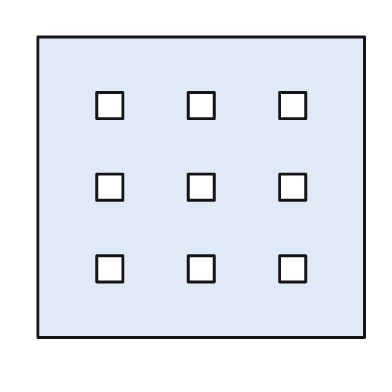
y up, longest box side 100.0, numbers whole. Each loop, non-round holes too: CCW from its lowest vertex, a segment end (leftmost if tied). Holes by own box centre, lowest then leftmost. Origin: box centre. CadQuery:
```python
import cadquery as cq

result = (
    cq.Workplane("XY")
    .moveTo(-50.0, -46.0)
    .lineTo(50.0, -46.0)
    .lineTo(50.0, 46.0)
    .lineTo(-50.0, 46.0)
    .close()
    .moveTo(-32.0, -29.0)
    .lineTo(-24.0, -29.0)
    .lineTo(-24.0, -21.0)
    .lineTo(-32.0, -21.0)
    .close()
    .moveTo(-4.0, -29.0)
    .lineTo(4.0, -29.0)
    .lineTo(4.0, -21.0)
    .lineTo(-4.0, -21.0)
    .close()
    .moveTo(24.0, -29.0)
    .lineTo(32.0, -29.0)
    .lineTo(32.0, -21.0)
    .lineTo(24.0, -21.0)
    .close()
    .moveTo(-32.0, -4.0)
    .lineTo(-24.0, -4.0)
    .lineTo(-24.0, 4.0)
    .lineTo(-32.0, 4.0)
    .close()
    .moveTo(-4.0, -4.0)
    .lineTo(4.0, -4.0)
    .lineTo(4.0, 4.0)
    .lineTo(-4.0, 4.0)
    .close()
    .moveTo(24.0, -4.0)
    .lineTo(32.0, -4.0)
    .lineTo(32.0, 4.0)
    .lineTo(24.0, 4.0)
    .close()
    .moveTo(-32.0, 21.0)
    .lineTo(-24.0, 21.0)
    .lineTo(-24.0, 29.0)
    .lineTo(-32.0, 29.0)
    .close()
    .moveTo(-4.0, 21.0)
    .lineTo(4.0, 21.0)
    .lineTo(4.0, 29.0)
    .lineTo(-4.0, 29.0)
    .close()
    .moveTo(24.0, 21.0)
    .lineTo(32.0, 21.0)
    .lineTo(32.0, 29.0)
    .lineTo(24.0, 29.0)
    .close()
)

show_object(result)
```